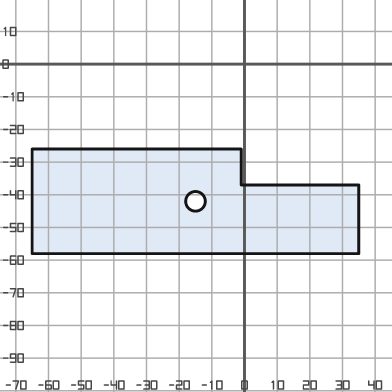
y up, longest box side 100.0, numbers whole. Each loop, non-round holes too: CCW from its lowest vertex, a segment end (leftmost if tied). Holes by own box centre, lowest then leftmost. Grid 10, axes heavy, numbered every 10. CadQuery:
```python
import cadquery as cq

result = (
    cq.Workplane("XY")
    .moveTo(-65.0, -58.0)
    .lineTo(35.0, -58.0)
    .lineTo(35.0, -37.0)
    .lineTo(-1.0, -37.0)
    .lineTo(-1.0, -26.0)
    .lineTo(-65.0, -26.0)
    .close()
    .moveTo(-15.0, -42.0)
    .circle(3.0)
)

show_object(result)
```